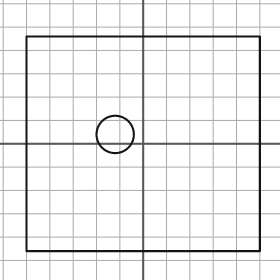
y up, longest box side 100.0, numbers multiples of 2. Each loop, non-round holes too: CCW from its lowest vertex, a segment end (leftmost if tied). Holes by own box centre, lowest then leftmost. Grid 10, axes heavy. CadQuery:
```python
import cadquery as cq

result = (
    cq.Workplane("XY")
    .moveTo(-50.0, -46.0)
    .lineTo(50.0, -46.0)
    .lineTo(50.0, 46.0)
    .lineTo(-50.0, 46.0)
    .close()
    .moveTo(-12.0, 4.0)
    .circle(8.0)
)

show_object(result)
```